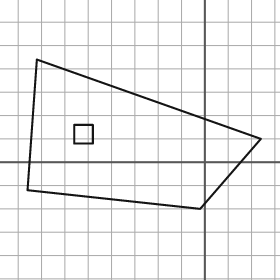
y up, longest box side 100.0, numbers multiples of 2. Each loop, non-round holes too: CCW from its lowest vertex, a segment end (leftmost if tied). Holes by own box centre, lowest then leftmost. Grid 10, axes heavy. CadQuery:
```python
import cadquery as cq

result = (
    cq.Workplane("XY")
    .moveTo(-2.0, -20.0)
    .lineTo(24.0, 10.0)
    .lineTo(-72.0, 44.0)
    .lineTo(-76.0, -12.0)
    .close()
    .moveTo(-56.0, 8.0)
    .lineTo(-48.0, 8.0)
    .lineTo(-48.0, 16.0)
    .lineTo(-56.0, 16.0)
    .close()
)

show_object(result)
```